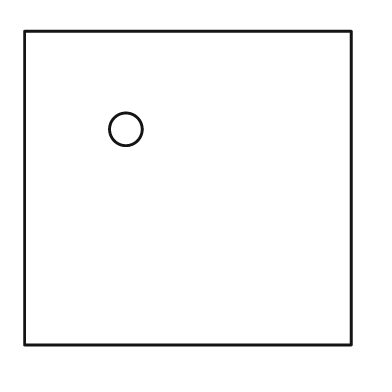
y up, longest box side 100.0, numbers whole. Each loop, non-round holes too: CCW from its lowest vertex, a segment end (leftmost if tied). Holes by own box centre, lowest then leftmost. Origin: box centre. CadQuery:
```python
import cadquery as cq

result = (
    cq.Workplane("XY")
    .moveTo(-50.0, -48.0)
    .lineTo(50.0, -48.0)
    .lineTo(50.0, 48.0)
    .lineTo(-50.0, 48.0)
    .close()
    .moveTo(-19.0, 18.0)
    .circle(5.0)
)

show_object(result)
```